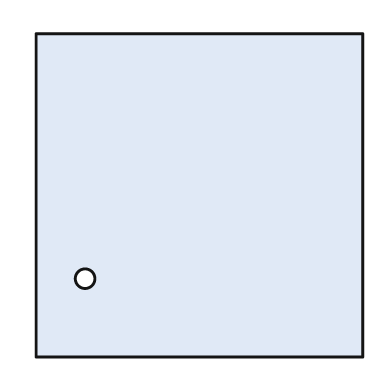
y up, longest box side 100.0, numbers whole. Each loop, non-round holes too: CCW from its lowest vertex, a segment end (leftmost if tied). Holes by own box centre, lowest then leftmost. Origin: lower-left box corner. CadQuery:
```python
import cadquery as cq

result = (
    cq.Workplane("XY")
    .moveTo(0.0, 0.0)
    .lineTo(100.0, 0.0)
    .lineTo(100.0, 99.0)
    .lineTo(0.0, 99.0)
    .close()
    .moveTo(15.0, 24.0)
    .circle(3.0)
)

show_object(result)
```